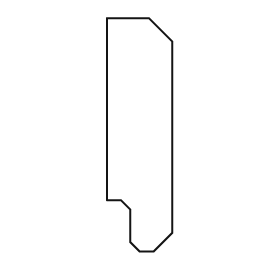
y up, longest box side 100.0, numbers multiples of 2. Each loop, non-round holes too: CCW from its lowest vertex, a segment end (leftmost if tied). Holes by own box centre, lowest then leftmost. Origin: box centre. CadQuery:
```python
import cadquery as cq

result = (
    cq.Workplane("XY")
    .moveTo(0.0, -50.0)
    .lineTo(6.0, -50.0)
    .lineTo(14.0, -42.0)
    .lineTo(14.0, 40.0)
    .lineTo(4.0, 50.0)
    .lineTo(-14.0, 50.0)
    .lineTo(-14.0, -28.0)
    .lineTo(-8.0, -28.0)
    .lineTo(-4.0, -32.0)
    .lineTo(-4.0, -46.0)
    .close()
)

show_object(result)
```